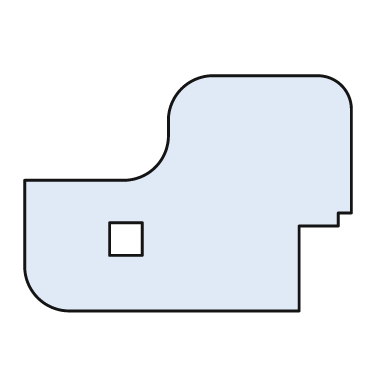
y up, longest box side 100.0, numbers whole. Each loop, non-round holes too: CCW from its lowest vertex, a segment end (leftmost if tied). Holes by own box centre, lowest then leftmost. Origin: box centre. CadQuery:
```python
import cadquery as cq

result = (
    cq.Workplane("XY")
    .moveTo(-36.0, -36.0)
    .lineTo(34.0, -36.0)
    .lineTo(34.0, -10.0)
    .lineTo(46.0, -10.0)
    .lineTo(46.0, -6.0)
    .lineTo(50.0, -6.0)
    .lineTo(50.0, 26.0)
    .threePointArc((47.0, 33.0), (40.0, 36.0))
    .lineTo(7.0, 36.0)
    .threePointArc((-2.0, 32.0), (-6.0, 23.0))
    .lineTo(-6.0, 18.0)
    .threePointArc((-10.0, 8.0), (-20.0, 4.0))
    .lineTo(-50.0, 4.0)
    .lineTo(-50.0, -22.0)
    .threePointArc((-46.0, -32.0), (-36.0, -36.0))
    .close()
    .moveTo(-24.0, -19.0)
    .lineTo(-14.0, -19.0)
    .lineTo(-14.0, -9.0)
    .lineTo(-24.0, -9.0)
    .close()
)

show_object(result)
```